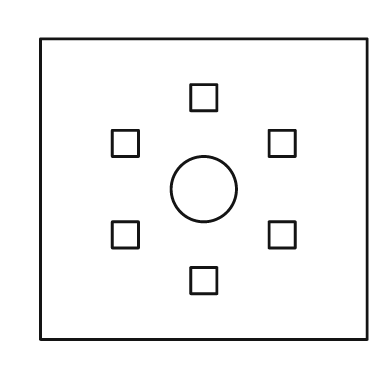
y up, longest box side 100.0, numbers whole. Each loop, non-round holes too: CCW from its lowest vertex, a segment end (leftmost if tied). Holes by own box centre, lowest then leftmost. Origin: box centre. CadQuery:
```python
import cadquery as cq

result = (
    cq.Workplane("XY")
    .moveTo(-50.0, -46.0)
    .lineTo(50.0, -46.0)
    .lineTo(50.0, 46.0)
    .lineTo(-50.0, 46.0)
    .close()
    .moveTo(-4.0, -32.0)
    .lineTo(4.0, -32.0)
    .lineTo(4.0, -24.0)
    .lineTo(-4.0, -24.0)
    .close()
    .moveTo(-28.0, -18.0)
    .lineTo(-20.0, -18.0)
    .lineTo(-20.0, -10.0)
    .lineTo(-28.0, -10.0)
    .close()
    .moveTo(20.0, -18.0)
    .lineTo(28.0, -18.0)
    .lineTo(28.0, -10.0)
    .lineTo(20.0, -10.0)
    .close()
    .moveTo(0.0, 0.0)
    .circle(10.0)
    .moveTo(-28.0, 10.0)
    .lineTo(-20.0, 10.0)
    .lineTo(-20.0, 18.0)
    .lineTo(-28.0, 18.0)
    .close()
    .moveTo(20.0, 10.0)
    .lineTo(28.0, 10.0)
    .lineTo(28.0, 18.0)
    .lineTo(20.0, 18.0)
    .close()
    .moveTo(-4.0, 24.0)
    .lineTo(4.0, 24.0)
    .lineTo(4.0, 32.0)
    .lineTo(-4.0, 32.0)
    .close()
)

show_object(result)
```